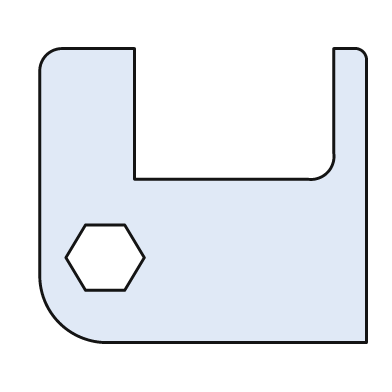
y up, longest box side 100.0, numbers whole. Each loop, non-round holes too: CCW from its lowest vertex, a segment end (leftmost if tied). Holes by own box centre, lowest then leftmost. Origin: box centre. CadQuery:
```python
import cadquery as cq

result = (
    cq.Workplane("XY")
    .moveTo(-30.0, -45.0)
    .lineTo(50.0, -45.0)
    .lineTo(50.0, 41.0)
    .threePointArc((49.0, 44.0), (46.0, 45.0))
    .lineTo(40.0, 45.0)
    .lineTo(40.0, 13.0)
    .threePointArc((38.0, 7.0), (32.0, 5.0))
    .lineTo(-21.0, 5.0)
    .lineTo(-21.0, 45.0)
    .lineTo(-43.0, 45.0)
    .threePointArc((-48.0, 43.0), (-50.0, 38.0))
    .lineTo(-50.0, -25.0)
    .threePointArc((-44.0, -39.0), (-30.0, -45.0))
    .close()
    .moveTo(-36.0, -29.0)
    .lineTo(-24.0, -29.0)
    .lineTo(-18.0, -19.0)
    .lineTo(-24.0, -9.0)
    .lineTo(-36.0, -9.0)
    .lineTo(-42.0, -19.0)
    .close()
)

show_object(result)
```